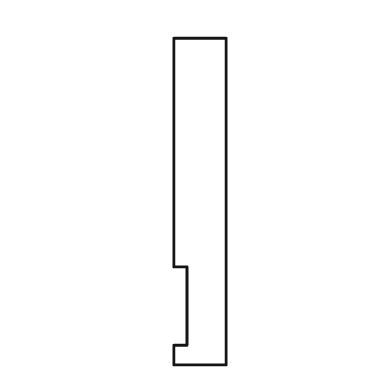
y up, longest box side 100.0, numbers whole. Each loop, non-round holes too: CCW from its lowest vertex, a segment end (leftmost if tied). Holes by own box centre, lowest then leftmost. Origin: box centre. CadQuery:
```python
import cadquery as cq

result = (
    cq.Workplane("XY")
    .moveTo(-8.0, -50.0)
    .lineTo(8.0, -50.0)
    .lineTo(8.0, 50.0)
    .lineTo(-8.0, 50.0)
    .lineTo(-8.0, -20.0)
    .lineTo(-4.0, -20.0)
    .lineTo(-4.0, -44.0)
    .lineTo(-8.0, -44.0)
    .close()
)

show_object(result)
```